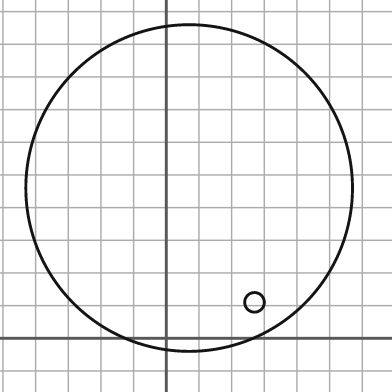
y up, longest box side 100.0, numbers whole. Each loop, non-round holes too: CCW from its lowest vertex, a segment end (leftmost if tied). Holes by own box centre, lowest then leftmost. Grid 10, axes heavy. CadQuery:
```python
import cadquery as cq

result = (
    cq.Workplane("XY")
    .moveTo(7.0, 46.0)
    .circle(50.0)
    .moveTo(27.0, 11.0)
    .circle(3.0)
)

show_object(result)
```